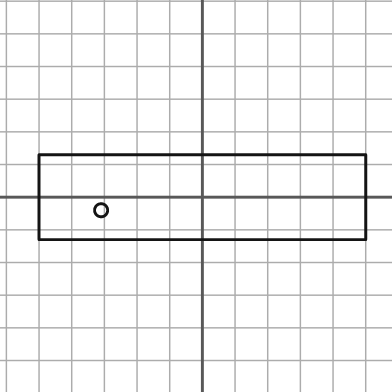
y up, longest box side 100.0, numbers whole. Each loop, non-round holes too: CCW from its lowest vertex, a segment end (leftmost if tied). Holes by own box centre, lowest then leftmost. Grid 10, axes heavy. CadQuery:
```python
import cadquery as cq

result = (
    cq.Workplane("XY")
    .moveTo(-50.0, -13.0)
    .lineTo(50.0, -13.0)
    .lineTo(50.0, 13.0)
    .lineTo(-50.0, 13.0)
    .close()
    .moveTo(-31.0, -4.0)
    .circle(2.0)
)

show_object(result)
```